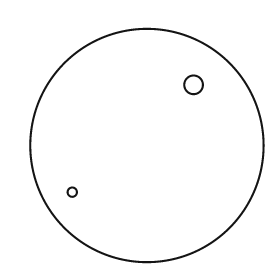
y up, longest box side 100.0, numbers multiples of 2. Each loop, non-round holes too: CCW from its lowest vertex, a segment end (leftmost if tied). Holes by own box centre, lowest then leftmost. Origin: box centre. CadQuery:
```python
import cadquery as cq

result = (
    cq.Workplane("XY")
    .moveTo(0.0, 0.0)
    .circle(50.0)
    .moveTo(-32.0, -20.0)
    .circle(2.0)
    .moveTo(20.0, 26.0)
    .circle(4.0)
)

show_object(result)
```